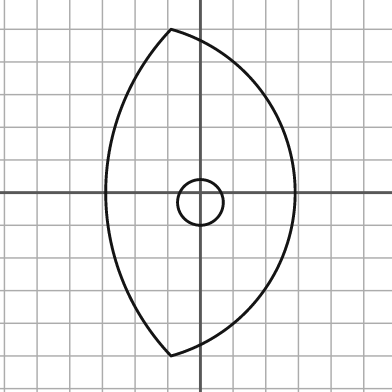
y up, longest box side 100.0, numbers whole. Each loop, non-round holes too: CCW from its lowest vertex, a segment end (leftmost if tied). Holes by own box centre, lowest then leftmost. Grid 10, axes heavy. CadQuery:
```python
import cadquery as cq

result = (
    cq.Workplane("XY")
    .moveTo(-9.0, -50.0)
    .threePointArc((29.0, 0.0), (-9.0, 50.0))
    .threePointArc((-29.0, 0.0), (-9.0, -50.0))
    .close()
    .moveTo(0.0, -3.0)
    .circle(7.0)
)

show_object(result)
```